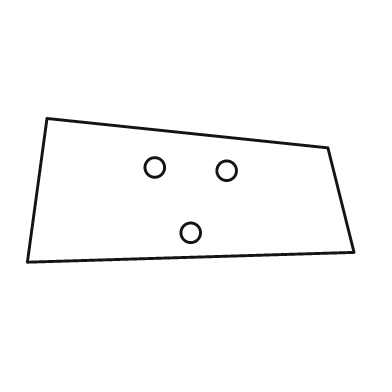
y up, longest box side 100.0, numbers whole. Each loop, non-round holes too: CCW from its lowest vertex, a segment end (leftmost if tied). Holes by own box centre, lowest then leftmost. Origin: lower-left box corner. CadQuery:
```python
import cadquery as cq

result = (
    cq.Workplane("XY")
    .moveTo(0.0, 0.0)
    .lineTo(100.0, 3.0)
    .lineTo(92.0, 35.0)
    .lineTo(6.0, 44.0)
    .close()
    .moveTo(50.0, 9.0)
    .circle(3.0)
    .moveTo(61.0, 28.0)
    .circle(3.0)
    .moveTo(39.0, 29.0)
    .circle(3.0)
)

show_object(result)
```